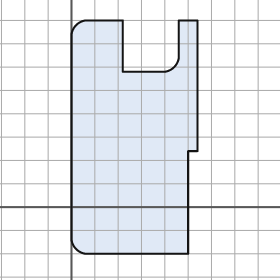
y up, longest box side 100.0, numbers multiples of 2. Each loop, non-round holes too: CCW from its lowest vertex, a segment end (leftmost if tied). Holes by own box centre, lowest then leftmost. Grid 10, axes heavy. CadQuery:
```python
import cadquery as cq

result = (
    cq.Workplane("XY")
    .moveTo(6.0, -20.0)
    .lineTo(50.0, -20.0)
    .lineTo(50.0, 24.0)
    .lineTo(54.0, 24.0)
    .lineTo(54.0, 80.0)
    .lineTo(46.0, 80.0)
    .lineTo(46.0, 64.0)
    .threePointArc((44.0, 60.0), (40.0, 58.0))
    .lineTo(22.0, 58.0)
    .lineTo(22.0, 80.0)
    .lineTo(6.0, 80.0)
    .threePointArc((2.0, 78.0), (0.0, 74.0))
    .lineTo(0.0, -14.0)
    .threePointArc((2.0, -18.0), (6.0, -20.0))
    .close()
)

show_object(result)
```